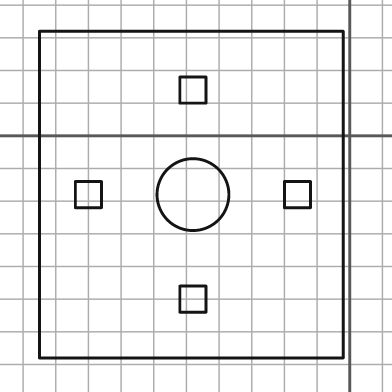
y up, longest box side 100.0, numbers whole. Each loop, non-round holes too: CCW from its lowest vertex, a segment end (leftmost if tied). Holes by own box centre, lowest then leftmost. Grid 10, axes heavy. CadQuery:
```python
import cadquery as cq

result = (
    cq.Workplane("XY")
    .moveTo(-95.0, -68.0)
    .lineTo(-2.0, -68.0)
    .lineTo(-2.0, 32.0)
    .lineTo(-95.0, 32.0)
    .close()
    .moveTo(-52.0, -54.0)
    .lineTo(-44.0, -54.0)
    .lineTo(-44.0, -46.0)
    .lineTo(-52.0, -46.0)
    .close()
    .moveTo(-84.0, -22.0)
    .lineTo(-76.0, -22.0)
    .lineTo(-76.0, -14.0)
    .lineTo(-84.0, -14.0)
    .close()
    .moveTo(-48.0, -18.0)
    .circle(11.0)
    .moveTo(-20.0, -22.0)
    .lineTo(-12.0, -22.0)
    .lineTo(-12.0, -14.0)
    .lineTo(-20.0, -14.0)
    .close()
    .moveTo(-52.0, 10.0)
    .lineTo(-44.0, 10.0)
    .lineTo(-44.0, 18.0)
    .lineTo(-52.0, 18.0)
    .close()
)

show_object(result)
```